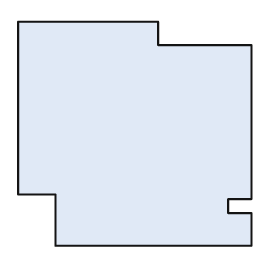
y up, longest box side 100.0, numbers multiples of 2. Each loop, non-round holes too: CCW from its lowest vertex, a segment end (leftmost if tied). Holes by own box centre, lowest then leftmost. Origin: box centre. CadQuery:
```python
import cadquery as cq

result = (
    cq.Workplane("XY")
    .moveTo(-34.0, -48.0)
    .lineTo(50.0, -48.0)
    .lineTo(50.0, -34.0)
    .lineTo(40.0, -34.0)
    .lineTo(40.0, -28.0)
    .lineTo(50.0, -28.0)
    .lineTo(50.0, 38.0)
    .lineTo(10.0, 38.0)
    .lineTo(10.0, 48.0)
    .lineTo(-50.0, 48.0)
    .lineTo(-50.0, -26.0)
    .lineTo(-34.0, -26.0)
    .close()
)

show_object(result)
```